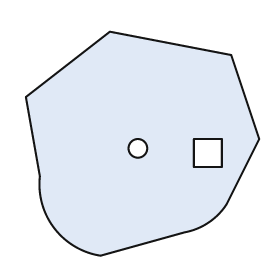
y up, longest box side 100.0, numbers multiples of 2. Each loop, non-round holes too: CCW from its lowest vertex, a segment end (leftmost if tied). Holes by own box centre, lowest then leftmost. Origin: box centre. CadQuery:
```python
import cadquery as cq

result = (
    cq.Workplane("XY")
    .moveTo(-18.0, -48.0)
    .lineTo(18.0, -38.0)
    .threePointArc((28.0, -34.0), (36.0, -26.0))
    .lineTo(50.0, 2.0)
    .lineTo(38.0, 38.0)
    .lineTo(-14.0, 48.0)
    .lineTo(-50.0, 20.0)
    .lineTo(-44.0, -14.0)
    .threePointArc((-38.0, -36.0), (-18.0, -48.0))
    .close()
    .moveTo(22.0, -10.0)
    .lineTo(34.0, -10.0)
    .lineTo(34.0, 2.0)
    .lineTo(22.0, 2.0)
    .close()
    .moveTo(-2.0, -2.0)
    .circle(4.0)
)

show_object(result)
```